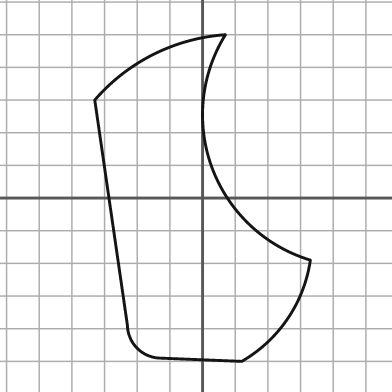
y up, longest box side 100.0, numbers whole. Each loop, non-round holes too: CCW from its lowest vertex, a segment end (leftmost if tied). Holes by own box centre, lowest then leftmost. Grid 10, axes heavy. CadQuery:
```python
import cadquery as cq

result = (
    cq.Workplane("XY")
    .moveTo(12.0, -50.0)
    .threePointArc((26.0, -37.0), (33.0, -19.0))
    .threePointArc((3.0, 9.0), (7.0, 50.0))
    .threePointArc((-15.0, 44.0), (-33.0, 30.0))
    .lineTo(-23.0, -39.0)
    .threePointArc((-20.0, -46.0), (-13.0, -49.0))
    .close()
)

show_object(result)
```